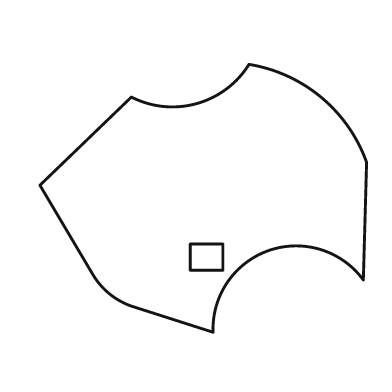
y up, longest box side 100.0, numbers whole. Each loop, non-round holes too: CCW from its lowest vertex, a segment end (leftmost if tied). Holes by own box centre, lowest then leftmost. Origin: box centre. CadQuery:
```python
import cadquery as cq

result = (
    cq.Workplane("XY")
    .moveTo(3.0, -41.0)
    .threePointArc((20.0, -16.0), (49.0, -25.0))
    .lineTo(50.0, 11.0)
    .threePointArc((36.0, 31.0), (14.0, 41.0))
    .threePointArc((-2.0, 29.0), (-22.0, 31.0))
    .lineTo(-50.0, 4.0)
    .lineTo(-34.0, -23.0)
    .threePointArc((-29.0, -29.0), (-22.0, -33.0))
    .close()
    .moveTo(-4.0, -22.0)
    .lineTo(6.0, -22.0)
    .lineTo(6.0, -14.0)
    .lineTo(-4.0, -14.0)
    .close()
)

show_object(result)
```